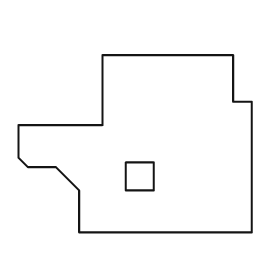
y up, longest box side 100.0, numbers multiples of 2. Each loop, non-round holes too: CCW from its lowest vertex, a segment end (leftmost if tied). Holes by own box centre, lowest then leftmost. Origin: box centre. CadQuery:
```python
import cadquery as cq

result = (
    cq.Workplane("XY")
    .moveTo(-24.0, -38.0)
    .lineTo(50.0, -38.0)
    .lineTo(50.0, 18.0)
    .lineTo(42.0, 18.0)
    .lineTo(42.0, 38.0)
    .lineTo(-14.0, 38.0)
    .lineTo(-14.0, 8.0)
    .lineTo(-50.0, 8.0)
    .lineTo(-50.0, -6.0)
    .lineTo(-46.0, -10.0)
    .lineTo(-34.0, -10.0)
    .lineTo(-24.0, -20.0)
    .close()
    .moveTo(-4.0, -20.0)
    .lineTo(8.0, -20.0)
    .lineTo(8.0, -8.0)
    .lineTo(-4.0, -8.0)
    .close()
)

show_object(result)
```